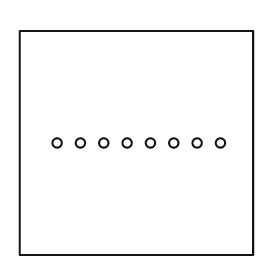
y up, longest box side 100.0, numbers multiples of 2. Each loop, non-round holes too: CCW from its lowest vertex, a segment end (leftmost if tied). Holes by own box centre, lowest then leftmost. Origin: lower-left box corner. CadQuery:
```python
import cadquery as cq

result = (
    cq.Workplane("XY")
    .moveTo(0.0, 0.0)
    .lineTo(100.0, 0.0)
    .lineTo(100.0, 96.0)
    .lineTo(0.0, 96.0)
    .close()
    .moveTo(16.0, 48.0)
    .circle(2.0)
    .moveTo(26.0, 48.0)
    .circle(2.0)
    .moveTo(36.0, 48.0)
    .circle(2.0)
    .moveTo(46.0, 48.0)
    .circle(2.0)
    .moveTo(56.0, 48.0)
    .circle(2.0)
    .moveTo(66.0, 48.0)
    .circle(2.0)
    .moveTo(76.0, 48.0)
    .circle(2.0)
    .moveTo(86.0, 48.0)
    .circle(2.0)
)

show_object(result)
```